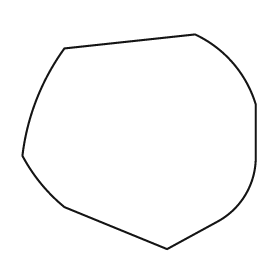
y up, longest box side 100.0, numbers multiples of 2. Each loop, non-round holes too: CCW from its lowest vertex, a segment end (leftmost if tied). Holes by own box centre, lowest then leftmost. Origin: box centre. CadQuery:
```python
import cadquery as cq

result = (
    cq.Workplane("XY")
    .moveTo(12.0, -46.0)
    .lineTo(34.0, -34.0)
    .threePointArc((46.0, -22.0), (50.0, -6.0))
    .lineTo(50.0, 16.0)
    .threePointArc((40.0, 34.0), (24.0, 46.0))
    .lineTo(-32.0, 40.0)
    .threePointArc((-44.0, 18.0), (-50.0, -6.0))
    .threePointArc((-42.0, -18.0), (-32.0, -28.0))
    .close()
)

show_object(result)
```